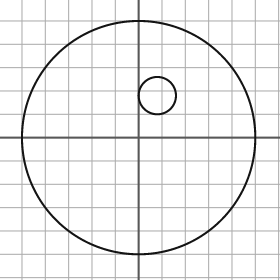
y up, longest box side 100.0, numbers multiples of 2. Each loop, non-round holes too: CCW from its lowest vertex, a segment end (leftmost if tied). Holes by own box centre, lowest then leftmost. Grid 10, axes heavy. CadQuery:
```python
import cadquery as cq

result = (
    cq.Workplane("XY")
    .moveTo(0.0, 0.0)
    .circle(50.0)
    .moveTo(8.0, 18.0)
    .circle(8.0)
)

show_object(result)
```